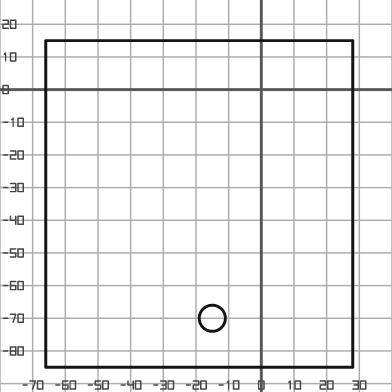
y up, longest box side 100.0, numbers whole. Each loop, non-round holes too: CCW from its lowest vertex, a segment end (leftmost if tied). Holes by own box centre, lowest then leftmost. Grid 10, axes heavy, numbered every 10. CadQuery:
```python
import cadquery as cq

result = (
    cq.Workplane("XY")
    .moveTo(-66.0, -85.0)
    .lineTo(28.0, -85.0)
    .lineTo(28.0, 15.0)
    .lineTo(-66.0, 15.0)
    .close()
    .moveTo(-15.0, -70.0)
    .circle(4.0)
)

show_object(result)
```